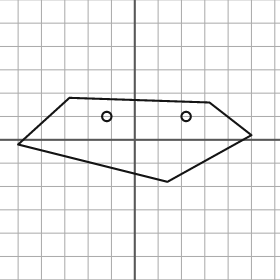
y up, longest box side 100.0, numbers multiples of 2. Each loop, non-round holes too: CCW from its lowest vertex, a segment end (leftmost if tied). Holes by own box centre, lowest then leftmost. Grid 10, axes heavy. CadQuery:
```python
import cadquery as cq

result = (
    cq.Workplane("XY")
    .moveTo(14.0, -18.0)
    .lineTo(50.0, 2.0)
    .lineTo(32.0, 16.0)
    .lineTo(-28.0, 18.0)
    .lineTo(-50.0, -2.0)
    .close()
    .moveTo(-12.0, 10.0)
    .circle(2.0)
    .moveTo(22.0, 10.0)
    .circle(2.0)
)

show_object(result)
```